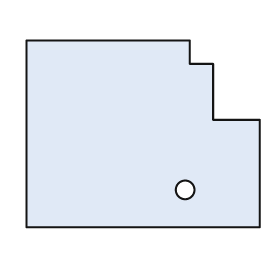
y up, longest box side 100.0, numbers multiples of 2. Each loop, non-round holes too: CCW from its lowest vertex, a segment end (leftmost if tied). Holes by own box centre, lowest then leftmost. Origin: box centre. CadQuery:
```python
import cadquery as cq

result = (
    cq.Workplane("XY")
    .moveTo(-50.0, -40.0)
    .lineTo(50.0, -40.0)
    .lineTo(50.0, 6.0)
    .lineTo(30.0, 6.0)
    .lineTo(30.0, 30.0)
    .lineTo(20.0, 30.0)
    .lineTo(20.0, 40.0)
    .lineTo(-50.0, 40.0)
    .close()
    .moveTo(18.0, -24.0)
    .circle(4.0)
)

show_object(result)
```